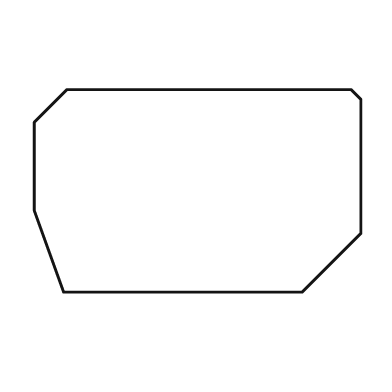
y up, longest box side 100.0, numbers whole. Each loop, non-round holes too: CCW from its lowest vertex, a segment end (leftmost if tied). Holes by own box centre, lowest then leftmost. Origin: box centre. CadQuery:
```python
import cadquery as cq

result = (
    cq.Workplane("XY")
    .moveTo(-41.0, -31.0)
    .lineTo(32.0, -31.0)
    .lineTo(50.0, -13.0)
    .lineTo(50.0, 28.0)
    .lineTo(47.0, 31.0)
    .lineTo(-40.0, 31.0)
    .lineTo(-50.0, 21.0)
    .lineTo(-50.0, -6.0)
    .close()
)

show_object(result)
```